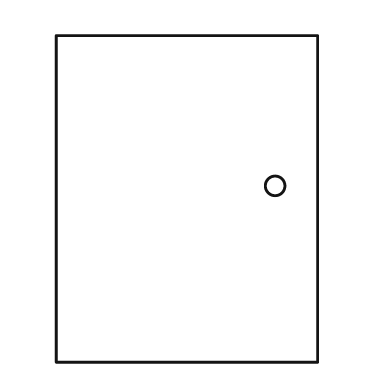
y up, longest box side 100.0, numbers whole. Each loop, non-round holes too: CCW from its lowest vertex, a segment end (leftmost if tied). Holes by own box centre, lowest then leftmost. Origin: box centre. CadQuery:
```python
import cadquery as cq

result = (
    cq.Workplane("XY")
    .moveTo(-40.0, -50.0)
    .lineTo(40.0, -50.0)
    .lineTo(40.0, 50.0)
    .lineTo(-40.0, 50.0)
    .close()
    .moveTo(27.0, 4.0)
    .circle(3.0)
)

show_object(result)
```